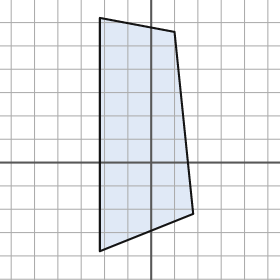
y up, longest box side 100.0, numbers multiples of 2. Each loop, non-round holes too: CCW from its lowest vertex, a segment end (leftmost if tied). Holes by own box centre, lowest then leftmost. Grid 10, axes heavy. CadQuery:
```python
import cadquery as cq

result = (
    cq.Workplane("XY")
    .moveTo(-22.0, -38.0)
    .lineTo(18.0, -22.0)
    .lineTo(10.0, 56.0)
    .lineTo(-22.0, 62.0)
    .close()
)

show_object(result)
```